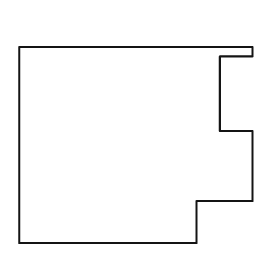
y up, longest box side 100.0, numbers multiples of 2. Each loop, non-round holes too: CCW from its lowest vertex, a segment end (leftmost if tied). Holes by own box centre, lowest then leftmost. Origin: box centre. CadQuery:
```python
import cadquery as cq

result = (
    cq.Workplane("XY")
    .moveTo(-50.0, -42.0)
    .lineTo(26.0, -42.0)
    .lineTo(26.0, -24.0)
    .lineTo(50.0, -24.0)
    .lineTo(50.0, 6.0)
    .lineTo(36.0, 6.0)
    .lineTo(36.0, 38.0)
    .lineTo(50.0, 38.0)
    .lineTo(50.0, 42.0)
    .lineTo(-50.0, 42.0)
    .close()
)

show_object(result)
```